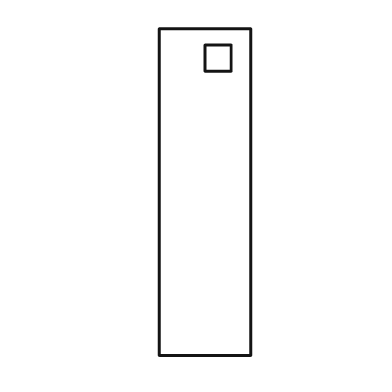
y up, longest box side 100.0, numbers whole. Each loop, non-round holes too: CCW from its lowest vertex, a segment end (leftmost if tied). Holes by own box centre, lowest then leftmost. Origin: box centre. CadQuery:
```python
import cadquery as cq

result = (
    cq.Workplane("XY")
    .moveTo(-14.0, -50.0)
    .lineTo(14.0, -50.0)
    .lineTo(14.0, 50.0)
    .lineTo(-14.0, 50.0)
    .close()
    .moveTo(0.0, 37.0)
    .lineTo(8.0, 37.0)
    .lineTo(8.0, 45.0)
    .lineTo(0.0, 45.0)
    .close()
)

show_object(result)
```